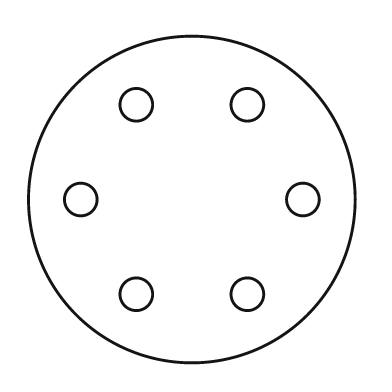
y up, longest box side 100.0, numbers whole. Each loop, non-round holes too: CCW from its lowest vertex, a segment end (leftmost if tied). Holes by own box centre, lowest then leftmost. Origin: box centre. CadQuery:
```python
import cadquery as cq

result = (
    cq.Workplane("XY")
    .moveTo(0.0, 0.0)
    .circle(50.0)
    .moveTo(-17.0, -29.0)
    .circle(5.0)
    .moveTo(17.0, -29.0)
    .circle(5.0)
    .moveTo(-34.0, 0.0)
    .circle(5.0)
    .moveTo(34.0, 0.0)
    .circle(5.0)
    .moveTo(-17.0, 29.0)
    .circle(5.0)
    .moveTo(17.0, 29.0)
    .circle(5.0)
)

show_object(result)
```